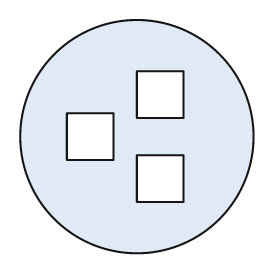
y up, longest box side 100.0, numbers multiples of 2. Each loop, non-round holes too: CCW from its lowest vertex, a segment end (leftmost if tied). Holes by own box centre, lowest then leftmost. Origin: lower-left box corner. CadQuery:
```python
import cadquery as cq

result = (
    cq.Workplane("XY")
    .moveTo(50.0, 50.0)
    .circle(50.0)
    .moveTo(50.0, 22.0)
    .lineTo(70.0, 22.0)
    .lineTo(70.0, 42.0)
    .lineTo(50.0, 42.0)
    .close()
    .moveTo(20.0, 40.0)
    .lineTo(40.0, 40.0)
    .lineTo(40.0, 60.0)
    .lineTo(20.0, 60.0)
    .close()
    .moveTo(50.0, 58.0)
    .lineTo(70.0, 58.0)
    .lineTo(70.0, 78.0)
    .lineTo(50.0, 78.0)
    .close()
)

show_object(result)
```